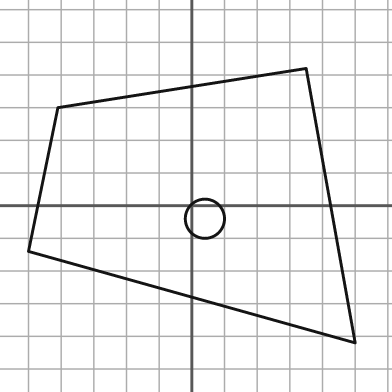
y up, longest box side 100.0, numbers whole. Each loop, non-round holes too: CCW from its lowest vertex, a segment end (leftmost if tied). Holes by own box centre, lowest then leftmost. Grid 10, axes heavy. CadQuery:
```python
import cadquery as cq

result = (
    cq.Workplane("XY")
    .moveTo(50.0, -42.0)
    .lineTo(35.0, 42.0)
    .lineTo(-41.0, 30.0)
    .lineTo(-50.0, -14.0)
    .close()
    .moveTo(4.0, -4.0)
    .circle(6.0)
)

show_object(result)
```